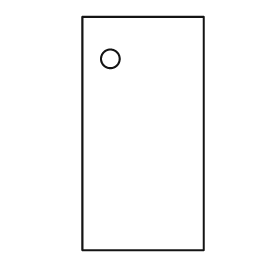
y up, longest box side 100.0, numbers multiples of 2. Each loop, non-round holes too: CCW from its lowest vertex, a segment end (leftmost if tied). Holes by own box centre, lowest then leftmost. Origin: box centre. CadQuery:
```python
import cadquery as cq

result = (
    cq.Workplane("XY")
    .moveTo(-26.0, -50.0)
    .lineTo(26.0, -50.0)
    .lineTo(26.0, 50.0)
    .lineTo(-26.0, 50.0)
    .close()
    .moveTo(-14.0, 32.0)
    .circle(4.0)
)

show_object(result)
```